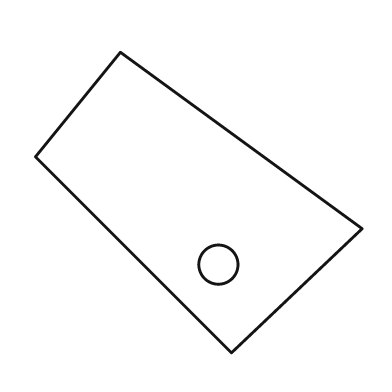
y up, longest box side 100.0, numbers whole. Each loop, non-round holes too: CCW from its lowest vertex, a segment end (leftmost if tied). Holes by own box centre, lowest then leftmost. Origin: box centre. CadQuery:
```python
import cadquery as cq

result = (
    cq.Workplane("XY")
    .moveTo(10.0, -46.0)
    .lineTo(50.0, -8.0)
    .lineTo(-24.0, 46.0)
    .lineTo(-50.0, 14.0)
    .close()
    .moveTo(6.0, -19.0)
    .circle(6.0)
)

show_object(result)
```